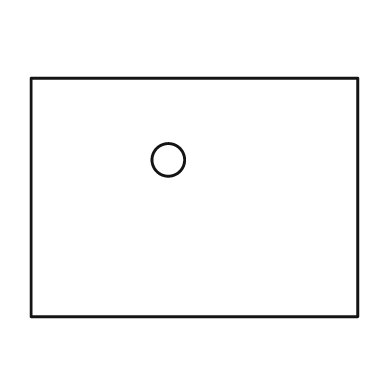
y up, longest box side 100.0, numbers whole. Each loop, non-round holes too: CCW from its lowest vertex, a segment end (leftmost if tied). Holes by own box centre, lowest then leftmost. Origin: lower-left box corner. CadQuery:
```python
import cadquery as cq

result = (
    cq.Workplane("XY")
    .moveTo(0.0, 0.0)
    .lineTo(100.0, 0.0)
    .lineTo(100.0, 73.0)
    .lineTo(0.0, 73.0)
    .close()
    .moveTo(42.0, 48.0)
    .circle(5.0)
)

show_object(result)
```